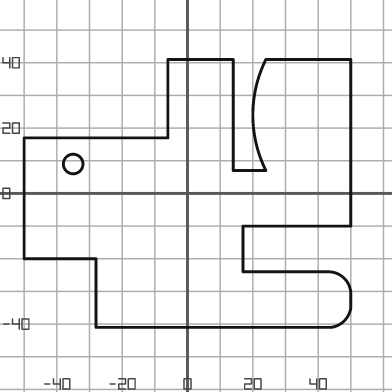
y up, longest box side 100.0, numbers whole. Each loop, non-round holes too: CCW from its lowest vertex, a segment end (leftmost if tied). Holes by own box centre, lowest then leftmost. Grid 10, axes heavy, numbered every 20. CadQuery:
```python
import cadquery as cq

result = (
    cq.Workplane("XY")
    .moveTo(-28.0, -41.0)
    .lineTo(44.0, -41.0)
    .threePointArc((48.0, -39.0), (50.0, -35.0))
    .lineTo(50.0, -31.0)
    .threePointArc((48.0, -26.0), (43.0, -24.0))
    .lineTo(17.0, -24.0)
    .lineTo(17.0, -10.0)
    .lineTo(50.0, -10.0)
    .lineTo(50.0, 41.0)
    .lineTo(24.0, 41.0)
    .threePointArc((20.0, 24.0), (24.0, 7.0))
    .lineTo(14.0, 7.0)
    .lineTo(14.0, 41.0)
    .lineTo(-6.0, 41.0)
    .lineTo(-6.0, 17.0)
    .lineTo(-50.0, 17.0)
    .lineTo(-50.0, -20.0)
    .lineTo(-28.0, -20.0)
    .close()
    .moveTo(-35.0, 9.0)
    .circle(3.0)
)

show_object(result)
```